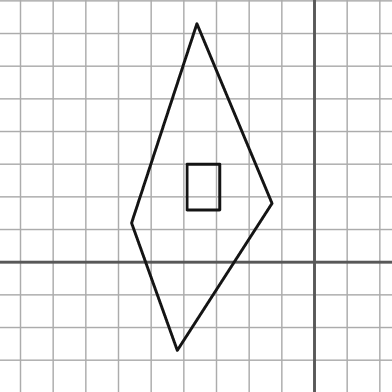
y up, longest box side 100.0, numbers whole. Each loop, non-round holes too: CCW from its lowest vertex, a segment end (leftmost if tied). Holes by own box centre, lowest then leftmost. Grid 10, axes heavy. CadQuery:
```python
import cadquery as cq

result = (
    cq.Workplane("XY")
    .moveTo(-42.0, -27.0)
    .lineTo(-13.0, 18.0)
    .lineTo(-36.0, 73.0)
    .lineTo(-56.0, 12.0)
    .close()
    .moveTo(-39.0, 16.0)
    .lineTo(-29.0, 16.0)
    .lineTo(-29.0, 30.0)
    .lineTo(-39.0, 30.0)
    .close()
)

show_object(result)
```